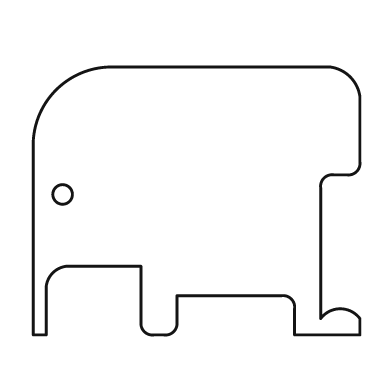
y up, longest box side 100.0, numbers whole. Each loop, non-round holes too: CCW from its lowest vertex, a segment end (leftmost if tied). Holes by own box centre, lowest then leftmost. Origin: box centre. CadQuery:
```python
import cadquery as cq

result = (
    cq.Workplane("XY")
    .moveTo(-50.0, -41.0)
    .lineTo(-46.0, -41.0)
    .lineTo(-46.0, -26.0)
    .threePointArc((-44.0, -22.0), (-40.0, -20.0))
    .lineTo(-17.0, -20.0)
    .lineTo(-17.0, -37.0)
    .threePointArc((-16.0, -40.0), (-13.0, -41.0))
    .lineTo(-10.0, -41.0)
    .threePointArc((-7.0, -40.0), (-6.0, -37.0))
    .lineTo(-6.0, -29.0)
    .lineTo(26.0, -29.0)
    .threePointArc((29.0, -30.0), (30.0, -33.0))
    .lineTo(30.0, -41.0)
    .lineTo(50.0, -41.0)
    .lineTo(50.0, -36.0)
    .threePointArc((44.0, -33.0), (38.0, -36.0))
    .lineTo(38.0, 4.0)
    .threePointArc((39.0, 7.0), (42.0, 8.0))
    .lineTo(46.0, 8.0)
    .threePointArc((49.0, 9.0), (50.0, 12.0))
    .lineTo(50.0, 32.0)
    .threePointArc((47.0, 38.0), (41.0, 41.0))
    .lineTo(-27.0, 41.0)
    .threePointArc((-43.0, 34.0), (-50.0, 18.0))
    .close()
    .moveTo(-41.0, 2.0)
    .circle(3.0)
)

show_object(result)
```